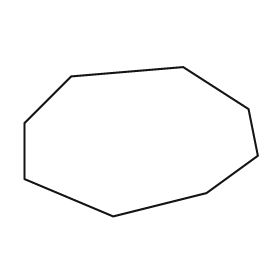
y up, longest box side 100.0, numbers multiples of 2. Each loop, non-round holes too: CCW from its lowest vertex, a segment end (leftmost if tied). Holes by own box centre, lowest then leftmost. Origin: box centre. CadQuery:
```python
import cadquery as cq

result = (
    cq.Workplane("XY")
    .moveTo(-12.0, -32.0)
    .lineTo(28.0, -22.0)
    .lineTo(50.0, -6.0)
    .lineTo(46.0, 14.0)
    .lineTo(18.0, 32.0)
    .lineTo(-30.0, 28.0)
    .lineTo(-50.0, 8.0)
    .lineTo(-50.0, -16.0)
    .close()
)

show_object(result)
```